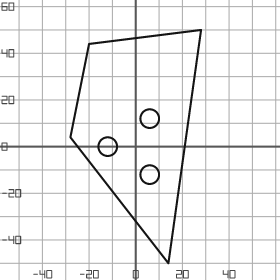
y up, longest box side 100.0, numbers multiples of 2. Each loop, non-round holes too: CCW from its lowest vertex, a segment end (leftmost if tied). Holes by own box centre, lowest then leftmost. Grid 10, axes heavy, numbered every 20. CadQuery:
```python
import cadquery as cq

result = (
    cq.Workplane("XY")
    .moveTo(14.0, -50.0)
    .lineTo(28.0, 50.0)
    .lineTo(-20.0, 44.0)
    .lineTo(-28.0, 4.0)
    .close()
    .moveTo(6.0, -12.0)
    .circle(4.0)
    .moveTo(-12.0, 0.0)
    .circle(4.0)
    .moveTo(6.0, 12.0)
    .circle(4.0)
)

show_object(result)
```